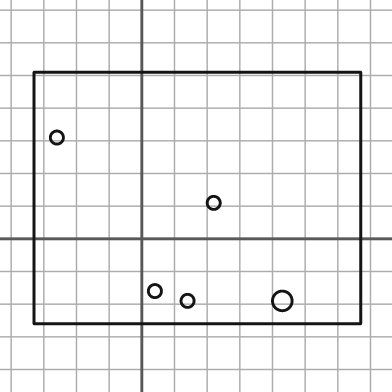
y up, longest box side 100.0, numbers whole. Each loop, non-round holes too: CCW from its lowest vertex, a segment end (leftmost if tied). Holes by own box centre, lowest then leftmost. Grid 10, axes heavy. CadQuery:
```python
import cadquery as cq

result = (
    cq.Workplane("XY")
    .moveTo(-33.0, -26.0)
    .lineTo(67.0, -26.0)
    .lineTo(67.0, 51.0)
    .lineTo(-33.0, 51.0)
    .close()
    .moveTo(14.0, -19.0)
    .circle(2.0)
    .moveTo(43.0, -19.0)
    .circle(3.0)
    .moveTo(4.0, -16.0)
    .circle(2.0)
    .moveTo(22.0, 11.0)
    .circle(2.0)
    .moveTo(-26.0, 31.0)
    .circle(2.0)
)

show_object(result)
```